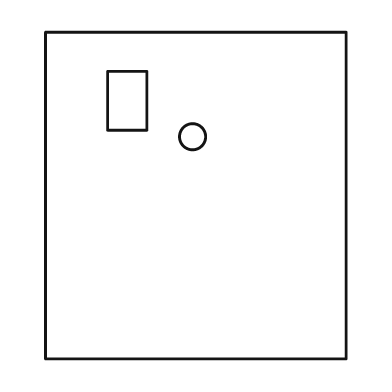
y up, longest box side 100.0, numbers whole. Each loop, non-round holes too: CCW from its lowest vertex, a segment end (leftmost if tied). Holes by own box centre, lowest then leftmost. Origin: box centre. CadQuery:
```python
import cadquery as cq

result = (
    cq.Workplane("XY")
    .moveTo(-46.0, -50.0)
    .lineTo(46.0, -50.0)
    .lineTo(46.0, 50.0)
    .lineTo(-46.0, 50.0)
    .close()
    .moveTo(-1.0, 18.0)
    .circle(4.0)
    .moveTo(-27.0, 20.0)
    .lineTo(-15.0, 20.0)
    .lineTo(-15.0, 38.0)
    .lineTo(-27.0, 38.0)
    .close()
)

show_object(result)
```